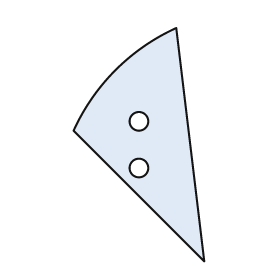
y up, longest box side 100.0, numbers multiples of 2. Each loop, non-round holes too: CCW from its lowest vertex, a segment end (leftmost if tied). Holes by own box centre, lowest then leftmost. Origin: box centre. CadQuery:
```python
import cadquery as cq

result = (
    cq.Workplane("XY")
    .moveTo(28.0, -50.0)
    .lineTo(16.0, 50.0)
    .threePointArc((-10.0, 32.0), (-28.0, 6.0))
    .close()
    .moveTo(0.0, -10.0)
    .circle(4.0)
    .moveTo(0.0, 10.0)
    .circle(4.0)
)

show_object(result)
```